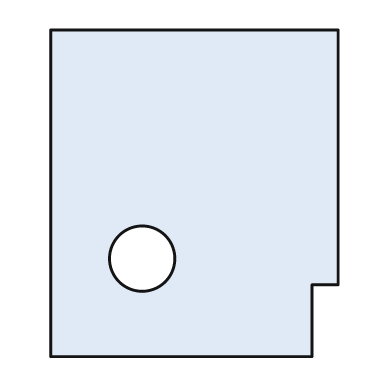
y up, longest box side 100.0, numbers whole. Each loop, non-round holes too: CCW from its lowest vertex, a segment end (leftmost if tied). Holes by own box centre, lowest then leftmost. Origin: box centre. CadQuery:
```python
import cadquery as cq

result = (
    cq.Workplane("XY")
    .moveTo(-44.0, -50.0)
    .lineTo(36.0, -50.0)
    .lineTo(36.0, -28.0)
    .lineTo(44.0, -28.0)
    .lineTo(44.0, 50.0)
    .lineTo(-44.0, 50.0)
    .close()
    .moveTo(-16.0, -20.0)
    .circle(10.0)
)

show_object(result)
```